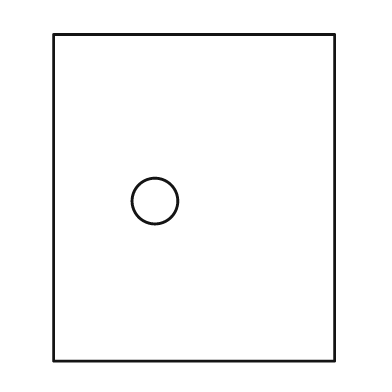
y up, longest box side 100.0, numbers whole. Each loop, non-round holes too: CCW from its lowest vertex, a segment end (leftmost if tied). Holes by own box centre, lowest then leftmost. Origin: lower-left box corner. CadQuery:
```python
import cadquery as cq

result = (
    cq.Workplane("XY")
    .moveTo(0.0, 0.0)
    .lineTo(86.0, 0.0)
    .lineTo(86.0, 100.0)
    .lineTo(0.0, 100.0)
    .close()
    .moveTo(31.0, 49.0)
    .circle(7.0)
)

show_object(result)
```